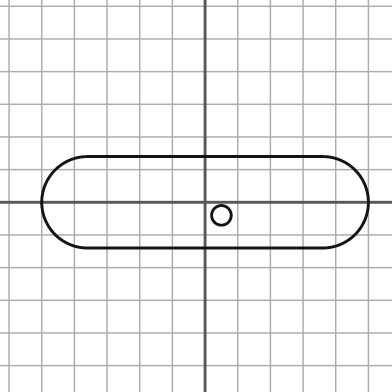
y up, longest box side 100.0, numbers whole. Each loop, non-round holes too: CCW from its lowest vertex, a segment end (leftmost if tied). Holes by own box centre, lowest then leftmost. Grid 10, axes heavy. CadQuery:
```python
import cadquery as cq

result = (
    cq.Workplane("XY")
    .moveTo(-36.0, -14.0)
    .lineTo(36.0, -14.0)
    .threePointArc((50.0, 0.0), (36.0, 14.0))
    .lineTo(-36.0, 14.0)
    .threePointArc((-50.0, 0.0), (-36.0, -14.0))
    .close()
    .moveTo(5.0, -4.0)
    .circle(3.0)
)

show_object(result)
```